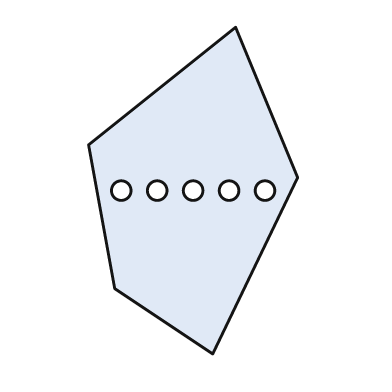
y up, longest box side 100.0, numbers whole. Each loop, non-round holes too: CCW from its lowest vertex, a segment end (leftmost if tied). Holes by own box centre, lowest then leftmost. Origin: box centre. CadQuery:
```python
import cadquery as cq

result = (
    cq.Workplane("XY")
    .moveTo(6.0, -50.0)
    .lineTo(32.0, 4.0)
    .lineTo(13.0, 50.0)
    .lineTo(-32.0, 14.0)
    .lineTo(-24.0, -30.0)
    .close()
    .moveTo(-22.0, 0.0)
    .circle(3.0)
    .moveTo(-11.0, 0.0)
    .circle(3.0)
    .moveTo(0.0, 0.0)
    .circle(3.0)
    .moveTo(11.0, 0.0)
    .circle(3.0)
    .moveTo(22.0, 0.0)
    .circle(3.0)
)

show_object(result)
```